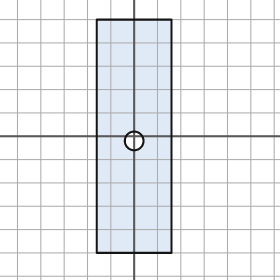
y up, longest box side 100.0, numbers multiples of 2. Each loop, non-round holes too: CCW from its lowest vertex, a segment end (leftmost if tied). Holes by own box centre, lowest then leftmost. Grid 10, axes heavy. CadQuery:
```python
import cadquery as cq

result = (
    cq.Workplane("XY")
    .moveTo(-16.0, -50.0)
    .lineTo(16.0, -50.0)
    .lineTo(16.0, 50.0)
    .lineTo(-16.0, 50.0)
    .close()
    .moveTo(0.0, -2.0)
    .circle(4.0)
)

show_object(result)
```